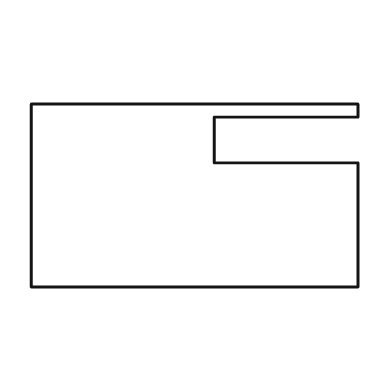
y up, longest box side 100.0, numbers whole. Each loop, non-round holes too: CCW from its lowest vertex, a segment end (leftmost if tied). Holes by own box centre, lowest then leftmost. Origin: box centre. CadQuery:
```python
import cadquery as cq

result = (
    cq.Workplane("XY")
    .moveTo(-50.0, -28.0)
    .lineTo(50.0, -28.0)
    .lineTo(50.0, 10.0)
    .lineTo(6.0, 10.0)
    .lineTo(6.0, 24.0)
    .lineTo(50.0, 24.0)
    .lineTo(50.0, 28.0)
    .lineTo(-50.0, 28.0)
    .close()
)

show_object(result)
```